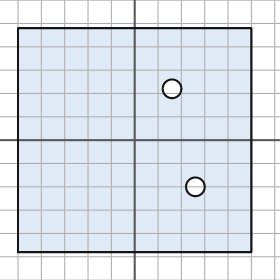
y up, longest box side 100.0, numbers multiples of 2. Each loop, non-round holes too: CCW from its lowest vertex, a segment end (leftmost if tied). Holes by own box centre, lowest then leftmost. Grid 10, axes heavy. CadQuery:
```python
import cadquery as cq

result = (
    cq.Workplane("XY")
    .moveTo(-50.0, -48.0)
    .lineTo(50.0, -48.0)
    .lineTo(50.0, 48.0)
    .lineTo(-50.0, 48.0)
    .close()
    .moveTo(26.0, -20.0)
    .circle(4.0)
    .moveTo(16.0, 22.0)
    .circle(4.0)
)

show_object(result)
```